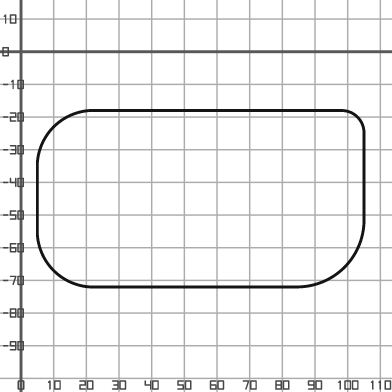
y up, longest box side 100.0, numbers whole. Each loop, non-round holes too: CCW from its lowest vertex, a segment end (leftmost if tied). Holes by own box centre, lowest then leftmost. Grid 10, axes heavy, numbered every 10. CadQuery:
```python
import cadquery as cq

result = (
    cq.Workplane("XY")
    .moveTo(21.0, -72.0)
    .lineTo(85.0, -72.0)
    .threePointArc((99.0, -66.0), (105.0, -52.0))
    .lineTo(105.0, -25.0)
    .threePointArc((103.0, -20.0), (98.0, -18.0))
    .lineTo(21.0, -18.0)
    .threePointArc((10.0, -23.0), (5.0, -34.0))
    .lineTo(5.0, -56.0)
    .threePointArc((10.0, -67.0), (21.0, -72.0))
    .close()
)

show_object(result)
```